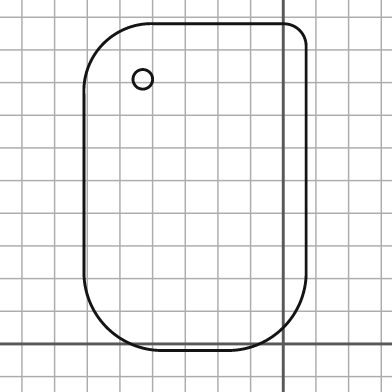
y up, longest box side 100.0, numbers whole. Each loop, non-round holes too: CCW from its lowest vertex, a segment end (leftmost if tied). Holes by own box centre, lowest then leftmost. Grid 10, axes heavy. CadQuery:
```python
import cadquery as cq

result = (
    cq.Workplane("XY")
    .moveTo(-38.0, -2.0)
    .lineTo(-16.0, -2.0)
    .threePointArc((0.0, 5.0), (7.0, 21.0))
    .lineTo(7.0, 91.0)
    .threePointArc((5.0, 96.0), (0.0, 98.0))
    .lineTo(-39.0, 98.0)
    .threePointArc((-55.0, 92.0), (-61.0, 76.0))
    .lineTo(-61.0, 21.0)
    .threePointArc((-54.0, 5.0), (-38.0, -2.0))
    .close()
    .moveTo(-43.0, 81.0)
    .circle(3.0)
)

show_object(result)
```